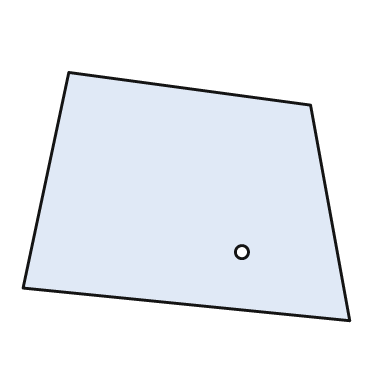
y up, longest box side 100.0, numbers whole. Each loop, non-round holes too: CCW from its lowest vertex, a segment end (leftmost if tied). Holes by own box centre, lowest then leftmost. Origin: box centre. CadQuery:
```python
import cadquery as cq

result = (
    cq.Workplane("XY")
    .moveTo(50.0, -38.0)
    .lineTo(38.0, 28.0)
    .lineTo(-36.0, 38.0)
    .lineTo(-50.0, -28.0)
    .close()
    .moveTo(17.0, -17.0)
    .circle(2.0)
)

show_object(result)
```